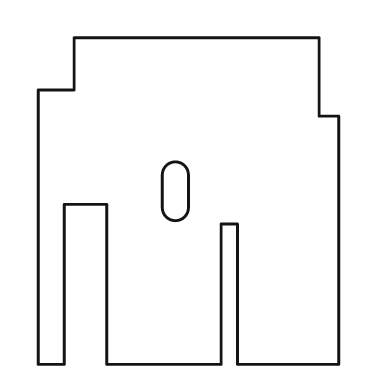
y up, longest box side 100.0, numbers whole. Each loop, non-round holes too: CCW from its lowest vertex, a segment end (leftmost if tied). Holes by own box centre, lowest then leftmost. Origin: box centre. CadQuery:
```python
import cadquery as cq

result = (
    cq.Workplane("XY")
    .moveTo(-46.0, -50.0)
    .lineTo(-38.0, -50.0)
    .lineTo(-38.0, -1.0)
    .lineTo(-25.0, -1.0)
    .lineTo(-25.0, -50.0)
    .lineTo(10.0, -50.0)
    .lineTo(10.0, -7.0)
    .lineTo(15.0, -7.0)
    .lineTo(15.0, -50.0)
    .lineTo(46.0, -50.0)
    .lineTo(46.0, 26.0)
    .lineTo(40.0, 26.0)
    .lineTo(40.0, 50.0)
    .lineTo(-35.0, 50.0)
    .lineTo(-35.0, 34.0)
    .lineTo(-46.0, 34.0)
    .close()
    .moveTo(-8.0, -2.0)
    .threePointArc((-4.0, -6.0), (0.0, -2.0))
    .lineTo(0.0, 8.0)
    .threePointArc((-4.0, 12.0), (-8.0, 8.0))
    .close()
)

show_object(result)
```